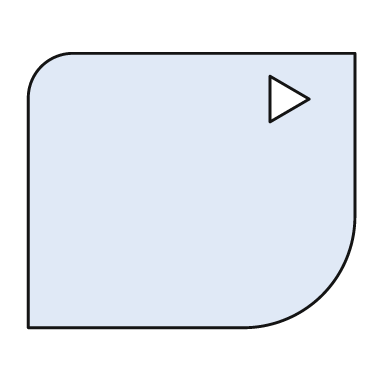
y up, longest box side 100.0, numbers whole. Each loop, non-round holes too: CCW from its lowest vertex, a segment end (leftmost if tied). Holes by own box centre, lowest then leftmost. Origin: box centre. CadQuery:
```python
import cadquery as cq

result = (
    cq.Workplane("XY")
    .moveTo(-50.0, -42.0)
    .lineTo(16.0, -42.0)
    .threePointArc((40.0, -32.0), (50.0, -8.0))
    .lineTo(50.0, 42.0)
    .lineTo(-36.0, 42.0)
    .threePointArc((-46.0, 38.0), (-50.0, 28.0))
    .close()
    .moveTo(24.0, 21.0)
    .lineTo(36.0, 28.0)
    .lineTo(24.0, 35.0)
    .close()
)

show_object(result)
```